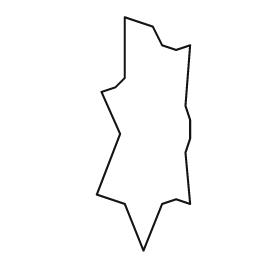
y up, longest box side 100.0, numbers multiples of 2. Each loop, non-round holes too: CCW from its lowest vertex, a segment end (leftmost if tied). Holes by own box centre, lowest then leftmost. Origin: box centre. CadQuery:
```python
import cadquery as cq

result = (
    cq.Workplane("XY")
    .moveTo(0.0, -50.0)
    .lineTo(8.0, -30.0)
    .lineTo(14.0, -28.0)
    .lineTo(20.0, -30.0)
    .lineTo(18.0, -8.0)
    .lineTo(20.0, -2.0)
    .lineTo(20.0, 6.0)
    .lineTo(18.0, 12.0)
    .lineTo(20.0, 38.0)
    .lineTo(14.0, 36.0)
    .lineTo(8.0, 38.0)
    .lineTo(4.0, 46.0)
    .lineTo(-8.0, 50.0)
    .lineTo(-8.0, 24.0)
    .lineTo(-12.0, 20.0)
    .lineTo(-18.0, 18.0)
    .lineTo(-10.0, 0.0)
    .lineTo(-20.0, -26.0)
    .lineTo(-8.0, -30.0)
    .close()
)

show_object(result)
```